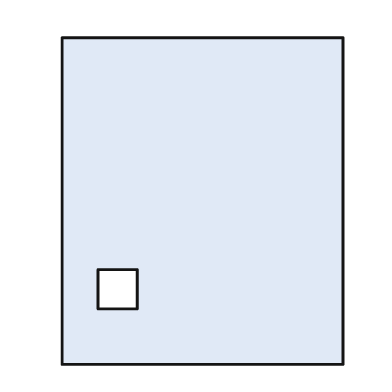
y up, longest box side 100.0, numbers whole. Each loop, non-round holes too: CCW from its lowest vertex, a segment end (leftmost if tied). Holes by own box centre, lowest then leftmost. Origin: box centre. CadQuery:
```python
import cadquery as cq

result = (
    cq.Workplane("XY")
    .moveTo(-43.0, -50.0)
    .lineTo(43.0, -50.0)
    .lineTo(43.0, 50.0)
    .lineTo(-43.0, 50.0)
    .close()
    .moveTo(-32.0, -33.0)
    .lineTo(-20.0, -33.0)
    .lineTo(-20.0, -21.0)
    .lineTo(-32.0, -21.0)
    .close()
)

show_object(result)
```